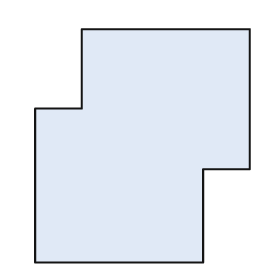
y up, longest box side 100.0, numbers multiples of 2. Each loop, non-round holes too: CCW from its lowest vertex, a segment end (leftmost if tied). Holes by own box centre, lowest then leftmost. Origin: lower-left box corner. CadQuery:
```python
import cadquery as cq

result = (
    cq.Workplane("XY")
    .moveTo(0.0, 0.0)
    .lineTo(72.0, 0.0)
    .lineTo(72.0, 40.0)
    .lineTo(92.0, 40.0)
    .lineTo(92.0, 100.0)
    .lineTo(20.0, 100.0)
    .lineTo(20.0, 66.0)
    .lineTo(0.0, 66.0)
    .close()
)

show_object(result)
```